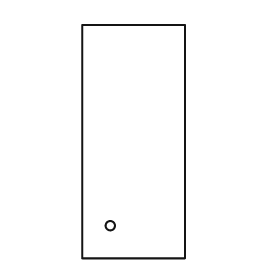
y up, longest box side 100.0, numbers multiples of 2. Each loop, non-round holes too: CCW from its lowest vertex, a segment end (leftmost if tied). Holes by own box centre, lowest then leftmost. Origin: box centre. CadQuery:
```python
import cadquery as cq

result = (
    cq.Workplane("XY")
    .moveTo(-22.0, -50.0)
    .lineTo(22.0, -50.0)
    .lineTo(22.0, 50.0)
    .lineTo(-22.0, 50.0)
    .close()
    .moveTo(-10.0, -36.0)
    .circle(2.0)
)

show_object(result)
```